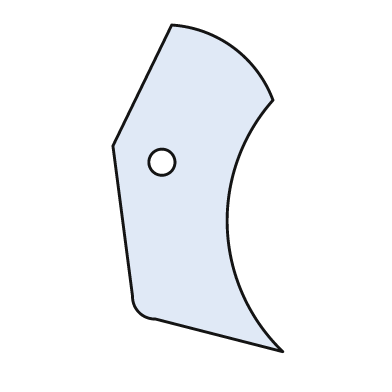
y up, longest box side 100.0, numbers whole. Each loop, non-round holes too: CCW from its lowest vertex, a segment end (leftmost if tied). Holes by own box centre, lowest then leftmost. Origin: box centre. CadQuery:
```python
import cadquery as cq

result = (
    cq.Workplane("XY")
    .moveTo(26.0, -50.0)
    .threePointArc((9.0, -12.0), (23.0, 27.0))
    .threePointArc((11.0, 43.0), (-8.0, 50.0))
    .lineTo(-26.0, 13.0)
    .lineTo(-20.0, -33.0)
    .threePointArc((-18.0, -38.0), (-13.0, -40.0))
    .close()
    .moveTo(-11.0, 8.0)
    .circle(4.0)
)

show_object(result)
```